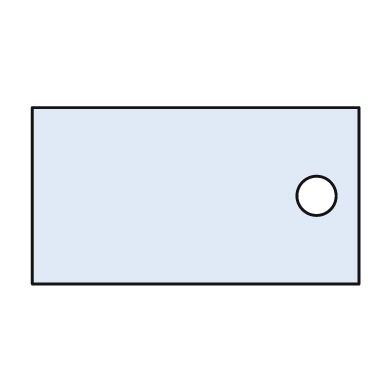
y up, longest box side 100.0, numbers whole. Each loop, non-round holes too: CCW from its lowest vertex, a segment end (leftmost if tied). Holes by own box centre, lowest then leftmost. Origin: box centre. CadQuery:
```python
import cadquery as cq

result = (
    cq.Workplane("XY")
    .moveTo(-50.0, -27.0)
    .lineTo(50.0, -27.0)
    .lineTo(50.0, 27.0)
    .lineTo(-50.0, 27.0)
    .close()
    .moveTo(37.0, 0.0)
    .circle(6.0)
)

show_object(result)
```